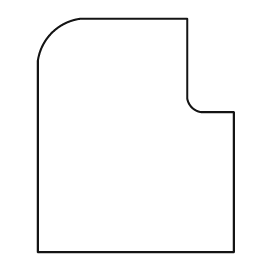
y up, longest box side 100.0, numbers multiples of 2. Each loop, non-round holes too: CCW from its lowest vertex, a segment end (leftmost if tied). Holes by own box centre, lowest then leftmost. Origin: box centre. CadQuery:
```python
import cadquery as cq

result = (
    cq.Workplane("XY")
    .moveTo(-42.0, -50.0)
    .lineTo(42.0, -50.0)
    .lineTo(42.0, 10.0)
    .lineTo(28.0, 10.0)
    .threePointArc((24.0, 12.0), (22.0, 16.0))
    .lineTo(22.0, 50.0)
    .lineTo(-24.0, 50.0)
    .threePointArc((-36.0, 44.0), (-42.0, 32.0))
    .close()
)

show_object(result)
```